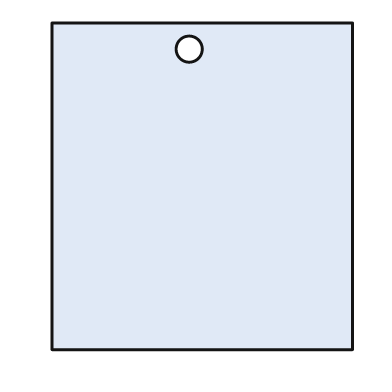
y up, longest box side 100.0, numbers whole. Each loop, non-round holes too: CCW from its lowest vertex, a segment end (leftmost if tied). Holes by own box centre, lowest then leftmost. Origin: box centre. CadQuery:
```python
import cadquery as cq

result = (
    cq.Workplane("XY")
    .moveTo(-46.0, -50.0)
    .lineTo(46.0, -50.0)
    .lineTo(46.0, 50.0)
    .lineTo(-46.0, 50.0)
    .close()
    .moveTo(-4.0, 42.0)
    .circle(4.0)
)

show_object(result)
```